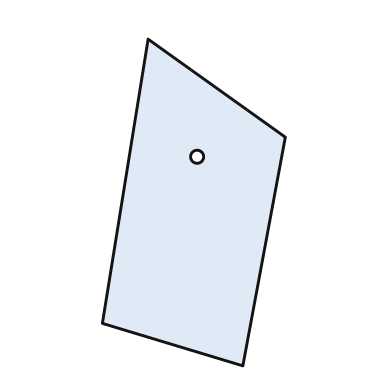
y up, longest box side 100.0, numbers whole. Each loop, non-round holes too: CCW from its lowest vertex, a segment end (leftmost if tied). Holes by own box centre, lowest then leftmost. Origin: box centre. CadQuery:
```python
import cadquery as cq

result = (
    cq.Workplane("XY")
    .moveTo(15.0, -50.0)
    .lineTo(28.0, 20.0)
    .lineTo(-14.0, 50.0)
    .lineTo(-28.0, -37.0)
    .close()
    .moveTo(1.0, 14.0)
    .circle(2.0)
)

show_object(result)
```